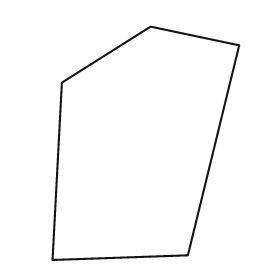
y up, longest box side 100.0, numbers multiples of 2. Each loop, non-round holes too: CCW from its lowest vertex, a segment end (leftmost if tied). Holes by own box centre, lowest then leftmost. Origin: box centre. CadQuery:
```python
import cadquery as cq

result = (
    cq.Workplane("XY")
    .moveTo(-40.0, -50.0)
    .lineTo(18.0, -48.0)
    .lineTo(40.0, 42.0)
    .lineTo(2.0, 50.0)
    .lineTo(-36.0, 26.0)
    .close()
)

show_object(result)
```